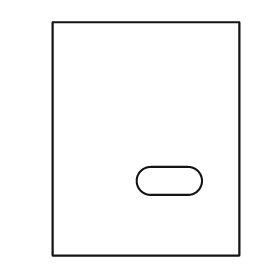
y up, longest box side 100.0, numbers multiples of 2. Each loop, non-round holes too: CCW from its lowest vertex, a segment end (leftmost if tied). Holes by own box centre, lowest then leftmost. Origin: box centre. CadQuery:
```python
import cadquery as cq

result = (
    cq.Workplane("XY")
    .moveTo(-40.0, -50.0)
    .lineTo(40.0, -50.0)
    .lineTo(40.0, 50.0)
    .lineTo(-40.0, 50.0)
    .close()
    .moveTo(2.0, -24.0)
    .lineTo(18.0, -24.0)
    .threePointArc((24.0, -18.0), (18.0, -12.0))
    .lineTo(2.0, -12.0)
    .threePointArc((-4.0, -18.0), (2.0, -24.0))
    .close()
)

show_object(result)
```